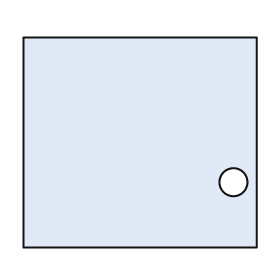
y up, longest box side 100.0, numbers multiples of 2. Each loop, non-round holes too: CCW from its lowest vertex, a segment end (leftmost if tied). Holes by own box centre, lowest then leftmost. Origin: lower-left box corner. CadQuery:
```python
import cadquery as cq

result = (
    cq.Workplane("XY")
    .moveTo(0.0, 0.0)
    .lineTo(100.0, 0.0)
    .lineTo(100.0, 90.0)
    .lineTo(0.0, 90.0)
    .close()
    .moveTo(90.0, 28.0)
    .circle(6.0)
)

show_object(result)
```